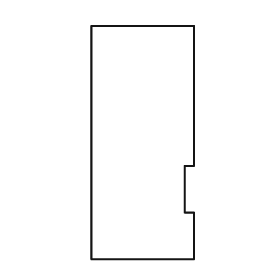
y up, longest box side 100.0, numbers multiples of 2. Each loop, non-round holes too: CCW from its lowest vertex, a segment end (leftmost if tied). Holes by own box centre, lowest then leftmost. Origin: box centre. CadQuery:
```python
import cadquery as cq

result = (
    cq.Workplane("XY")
    .moveTo(-22.0, -50.0)
    .lineTo(22.0, -50.0)
    .lineTo(22.0, -30.0)
    .lineTo(18.0, -30.0)
    .lineTo(18.0, -10.0)
    .lineTo(22.0, -10.0)
    .lineTo(22.0, 50.0)
    .lineTo(-22.0, 50.0)
    .close()
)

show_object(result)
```